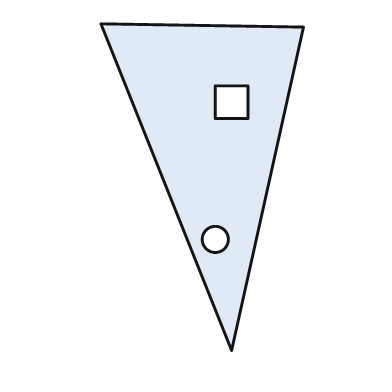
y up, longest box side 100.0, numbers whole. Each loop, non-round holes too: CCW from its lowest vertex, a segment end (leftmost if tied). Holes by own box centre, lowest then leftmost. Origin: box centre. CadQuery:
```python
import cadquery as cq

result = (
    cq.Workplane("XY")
    .moveTo(9.0, -50.0)
    .lineTo(31.0, 49.0)
    .lineTo(-31.0, 50.0)
    .close()
    .moveTo(4.0, -16.0)
    .circle(4.0)
    .moveTo(4.0, 21.0)
    .lineTo(14.0, 21.0)
    .lineTo(14.0, 31.0)
    .lineTo(4.0, 31.0)
    .close()
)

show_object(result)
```